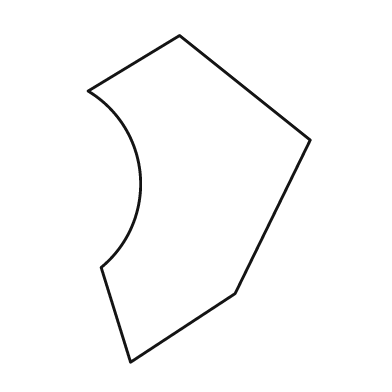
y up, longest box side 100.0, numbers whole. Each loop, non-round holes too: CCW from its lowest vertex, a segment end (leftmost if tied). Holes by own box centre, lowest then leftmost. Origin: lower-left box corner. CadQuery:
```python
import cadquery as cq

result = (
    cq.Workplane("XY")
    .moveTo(13.0, 0.0)
    .lineTo(45.0, 21.0)
    .lineTo(68.0, 68.0)
    .lineTo(28.0, 100.0)
    .lineTo(0.0, 83.0)
    .threePointArc((16.0, 57.0), (4.0, 29.0))
    .close()
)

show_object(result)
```